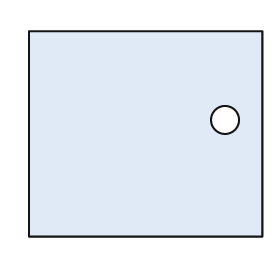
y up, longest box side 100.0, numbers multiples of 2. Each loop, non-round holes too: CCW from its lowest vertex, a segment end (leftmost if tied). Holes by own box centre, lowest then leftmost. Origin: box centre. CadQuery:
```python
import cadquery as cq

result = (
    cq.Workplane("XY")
    .moveTo(-50.0, -44.0)
    .lineTo(50.0, -44.0)
    .lineTo(50.0, 44.0)
    .lineTo(-50.0, 44.0)
    .close()
    .moveTo(34.0, 6.0)
    .circle(6.0)
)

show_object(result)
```